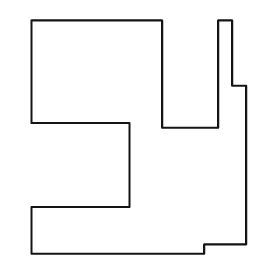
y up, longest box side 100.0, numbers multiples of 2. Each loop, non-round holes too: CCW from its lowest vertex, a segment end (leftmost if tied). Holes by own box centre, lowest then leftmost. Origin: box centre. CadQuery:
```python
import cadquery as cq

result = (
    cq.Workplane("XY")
    .moveTo(-46.0, -50.0)
    .lineTo(28.0, -50.0)
    .lineTo(28.0, -46.0)
    .lineTo(46.0, -46.0)
    .lineTo(46.0, 22.0)
    .lineTo(40.0, 22.0)
    .lineTo(40.0, 50.0)
    .lineTo(34.0, 50.0)
    .lineTo(34.0, 4.0)
    .lineTo(10.0, 4.0)
    .lineTo(10.0, 50.0)
    .lineTo(-46.0, 50.0)
    .lineTo(-46.0, 6.0)
    .lineTo(-4.0, 6.0)
    .lineTo(-4.0, -30.0)
    .lineTo(-46.0, -30.0)
    .close()
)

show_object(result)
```